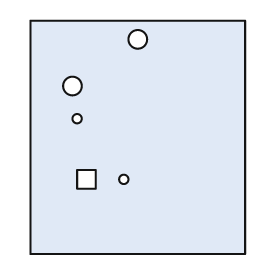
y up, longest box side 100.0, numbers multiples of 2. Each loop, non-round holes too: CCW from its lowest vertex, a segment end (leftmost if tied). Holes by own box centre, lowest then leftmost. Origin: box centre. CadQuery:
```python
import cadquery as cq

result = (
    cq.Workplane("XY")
    .moveTo(-46.0, -50.0)
    .lineTo(46.0, -50.0)
    .lineTo(46.0, 50.0)
    .lineTo(-46.0, 50.0)
    .close()
    .moveTo(-26.0, -22.0)
    .lineTo(-18.0, -22.0)
    .lineTo(-18.0, -14.0)
    .lineTo(-26.0, -14.0)
    .close()
    .moveTo(-6.0, -18.0)
    .circle(2.0)
    .moveTo(-26.0, 8.0)
    .circle(2.0)
    .moveTo(-28.0, 22.0)
    .circle(4.0)
    .moveTo(0.0, 42.0)
    .circle(4.0)
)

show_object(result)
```